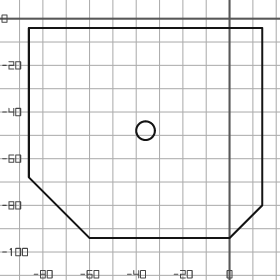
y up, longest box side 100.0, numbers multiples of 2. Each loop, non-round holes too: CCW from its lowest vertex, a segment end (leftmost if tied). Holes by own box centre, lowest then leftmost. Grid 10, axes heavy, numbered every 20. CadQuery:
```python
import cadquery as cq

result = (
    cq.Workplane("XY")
    .moveTo(-60.0, -94.0)
    .lineTo(0.0, -94.0)
    .lineTo(14.0, -80.0)
    .lineTo(14.0, -4.0)
    .lineTo(-86.0, -4.0)
    .lineTo(-86.0, -68.0)
    .close()
    .moveTo(-36.0, -48.0)
    .circle(4.0)
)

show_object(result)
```